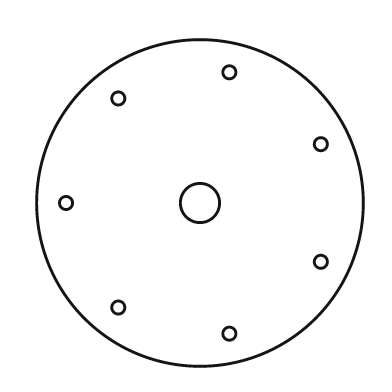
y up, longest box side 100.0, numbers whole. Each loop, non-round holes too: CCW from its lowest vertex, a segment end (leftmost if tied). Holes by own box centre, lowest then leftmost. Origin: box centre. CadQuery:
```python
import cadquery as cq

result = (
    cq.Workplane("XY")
    .moveTo(0.0, 0.0)
    .circle(50.0)
    .moveTo(9.0, -40.0)
    .circle(2.0)
    .moveTo(-25.0, -32.0)
    .circle(2.0)
    .moveTo(37.0, -18.0)
    .circle(2.0)
    .moveTo(-41.0, 0.0)
    .circle(2.0)
    .moveTo(0.0, 0.0)
    .circle(6.0)
    .moveTo(37.0, 18.0)
    .circle(2.0)
    .moveTo(-25.0, 32.0)
    .circle(2.0)
    .moveTo(9.0, 40.0)
    .circle(2.0)
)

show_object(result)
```